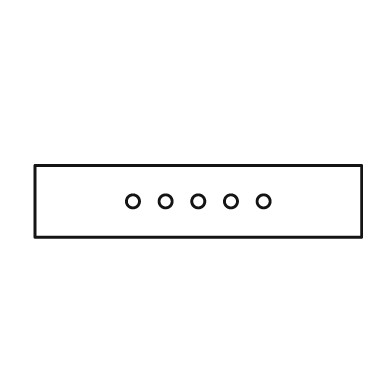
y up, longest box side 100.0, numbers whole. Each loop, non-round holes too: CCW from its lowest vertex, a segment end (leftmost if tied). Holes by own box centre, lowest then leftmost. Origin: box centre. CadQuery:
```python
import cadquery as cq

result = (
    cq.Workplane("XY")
    .moveTo(-50.0, -11.0)
    .lineTo(50.0, -11.0)
    .lineTo(50.0, 11.0)
    .lineTo(-50.0, 11.0)
    .close()
    .moveTo(-20.0, 0.0)
    .circle(2.0)
    .moveTo(-10.0, 0.0)
    .circle(2.0)
    .moveTo(0.0, 0.0)
    .circle(2.0)
    .moveTo(10.0, 0.0)
    .circle(2.0)
    .moveTo(20.0, 0.0)
    .circle(2.0)
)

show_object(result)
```